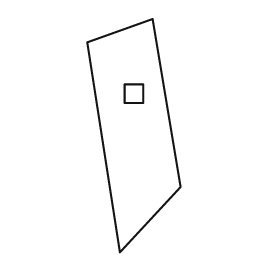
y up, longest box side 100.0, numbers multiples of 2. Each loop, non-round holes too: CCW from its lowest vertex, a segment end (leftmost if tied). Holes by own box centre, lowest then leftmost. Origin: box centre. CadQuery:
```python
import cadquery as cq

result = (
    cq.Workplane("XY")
    .moveTo(-6.0, -50.0)
    .lineTo(20.0, -22.0)
    .lineTo(8.0, 50.0)
    .lineTo(-20.0, 40.0)
    .close()
    .moveTo(-4.0, 14.0)
    .lineTo(4.0, 14.0)
    .lineTo(4.0, 22.0)
    .lineTo(-4.0, 22.0)
    .close()
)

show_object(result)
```